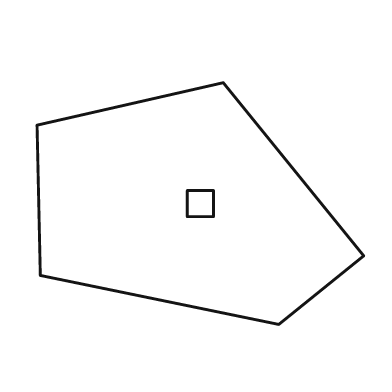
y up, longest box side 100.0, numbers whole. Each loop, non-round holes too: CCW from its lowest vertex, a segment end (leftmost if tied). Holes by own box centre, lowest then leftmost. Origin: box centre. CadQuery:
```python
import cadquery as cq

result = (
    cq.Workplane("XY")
    .moveTo(24.0, -37.0)
    .lineTo(50.0, -16.0)
    .lineTo(7.0, 37.0)
    .lineTo(-50.0, 24.0)
    .lineTo(-49.0, -22.0)
    .close()
    .moveTo(-4.0, -4.0)
    .lineTo(4.0, -4.0)
    .lineTo(4.0, 4.0)
    .lineTo(-4.0, 4.0)
    .close()
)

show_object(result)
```